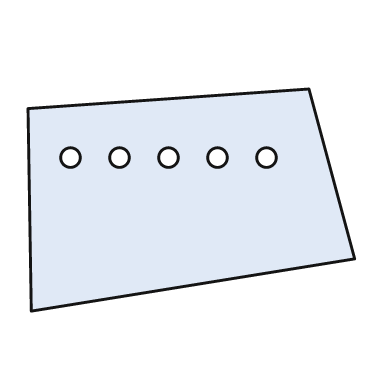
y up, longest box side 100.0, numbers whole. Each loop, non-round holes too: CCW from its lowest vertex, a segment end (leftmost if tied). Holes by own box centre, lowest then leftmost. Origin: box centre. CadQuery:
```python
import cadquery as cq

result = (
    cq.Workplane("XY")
    .moveTo(-49.0, -34.0)
    .lineTo(50.0, -18.0)
    .lineTo(36.0, 34.0)
    .lineTo(-50.0, 28.0)
    .close()
    .moveTo(-37.0, 13.0)
    .circle(3.0)
    .moveTo(-22.0, 13.0)
    .circle(3.0)
    .moveTo(-7.0, 13.0)
    .circle(3.0)
    .moveTo(8.0, 13.0)
    .circle(3.0)
    .moveTo(23.0, 13.0)
    .circle(3.0)
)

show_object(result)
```